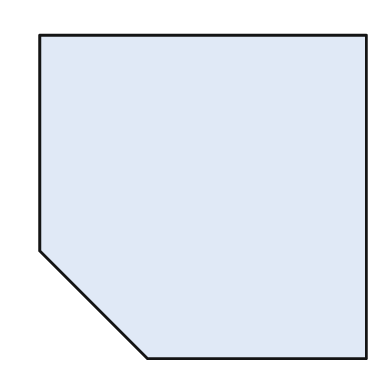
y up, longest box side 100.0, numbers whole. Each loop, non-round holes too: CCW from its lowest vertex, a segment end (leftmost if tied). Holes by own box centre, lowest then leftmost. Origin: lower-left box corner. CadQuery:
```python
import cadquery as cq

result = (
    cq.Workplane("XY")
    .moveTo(33.0, 0.0)
    .lineTo(100.0, 0.0)
    .lineTo(100.0, 99.0)
    .lineTo(0.0, 99.0)
    .lineTo(0.0, 33.0)
    .close()
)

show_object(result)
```